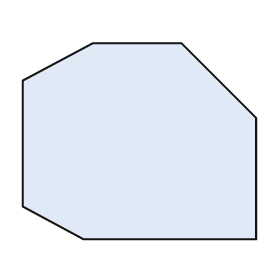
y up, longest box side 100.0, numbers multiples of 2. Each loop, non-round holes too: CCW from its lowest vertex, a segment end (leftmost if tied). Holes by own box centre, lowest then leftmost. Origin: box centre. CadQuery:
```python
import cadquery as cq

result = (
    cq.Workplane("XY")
    .moveTo(-24.0, -42.0)
    .lineTo(50.0, -42.0)
    .lineTo(50.0, 10.0)
    .lineTo(18.0, 42.0)
    .lineTo(-20.0, 42.0)
    .lineTo(-50.0, 26.0)
    .lineTo(-50.0, -28.0)
    .close()
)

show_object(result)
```